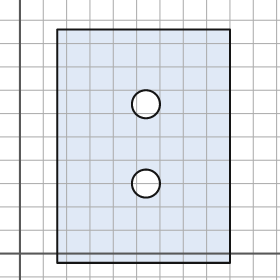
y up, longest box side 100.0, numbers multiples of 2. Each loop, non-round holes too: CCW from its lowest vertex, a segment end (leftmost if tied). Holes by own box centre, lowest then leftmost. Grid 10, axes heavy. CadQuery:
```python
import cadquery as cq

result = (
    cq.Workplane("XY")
    .moveTo(16.0, -4.0)
    .lineTo(90.0, -4.0)
    .lineTo(90.0, 96.0)
    .lineTo(16.0, 96.0)
    .close()
    .moveTo(54.0, 30.0)
    .circle(6.0)
    .moveTo(54.0, 64.0)
    .circle(6.0)
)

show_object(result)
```